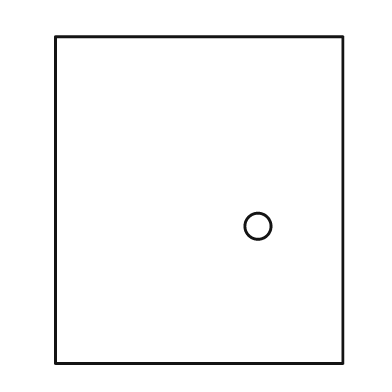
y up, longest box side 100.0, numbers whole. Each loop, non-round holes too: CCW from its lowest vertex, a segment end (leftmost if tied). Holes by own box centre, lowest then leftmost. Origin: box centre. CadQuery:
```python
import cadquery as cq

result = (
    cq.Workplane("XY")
    .moveTo(-44.0, -50.0)
    .lineTo(44.0, -50.0)
    .lineTo(44.0, 50.0)
    .lineTo(-44.0, 50.0)
    .close()
    .moveTo(18.0, -8.0)
    .circle(4.0)
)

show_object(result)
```